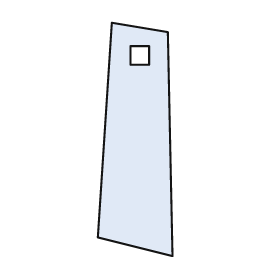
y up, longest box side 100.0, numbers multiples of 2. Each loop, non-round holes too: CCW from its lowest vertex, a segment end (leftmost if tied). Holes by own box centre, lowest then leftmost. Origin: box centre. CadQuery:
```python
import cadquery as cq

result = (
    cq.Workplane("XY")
    .moveTo(16.0, -50.0)
    .lineTo(14.0, 46.0)
    .lineTo(-10.0, 50.0)
    .lineTo(-16.0, -42.0)
    .close()
    .moveTo(-2.0, 32.0)
    .lineTo(6.0, 32.0)
    .lineTo(6.0, 40.0)
    .lineTo(-2.0, 40.0)
    .close()
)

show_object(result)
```